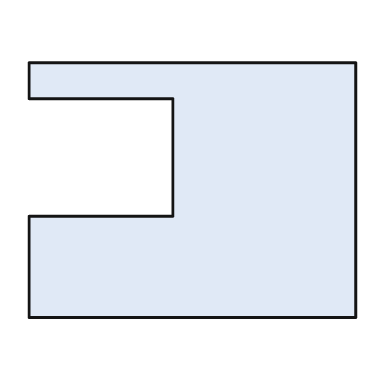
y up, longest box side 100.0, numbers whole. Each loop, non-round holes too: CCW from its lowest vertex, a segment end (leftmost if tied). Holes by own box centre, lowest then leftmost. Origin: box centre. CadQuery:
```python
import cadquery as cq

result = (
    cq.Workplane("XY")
    .moveTo(-50.0, -39.0)
    .lineTo(50.0, -39.0)
    .lineTo(50.0, 39.0)
    .lineTo(-50.0, 39.0)
    .lineTo(-50.0, 28.0)
    .lineTo(-6.0, 28.0)
    .lineTo(-6.0, -8.0)
    .lineTo(-50.0, -8.0)
    .close()
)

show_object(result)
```